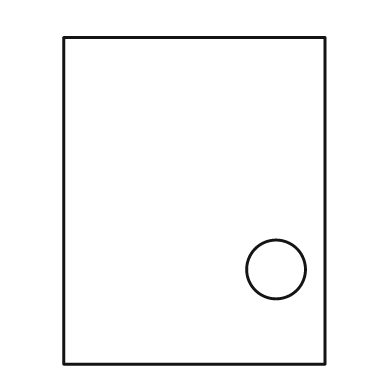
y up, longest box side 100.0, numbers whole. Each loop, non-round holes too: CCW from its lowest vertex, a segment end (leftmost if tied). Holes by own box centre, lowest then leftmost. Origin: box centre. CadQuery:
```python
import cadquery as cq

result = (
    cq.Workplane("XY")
    .moveTo(-40.0, -50.0)
    .lineTo(40.0, -50.0)
    .lineTo(40.0, 50.0)
    .lineTo(-40.0, 50.0)
    .close()
    .moveTo(25.0, -21.0)
    .circle(9.0)
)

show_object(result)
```